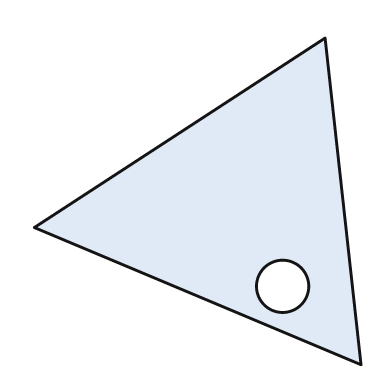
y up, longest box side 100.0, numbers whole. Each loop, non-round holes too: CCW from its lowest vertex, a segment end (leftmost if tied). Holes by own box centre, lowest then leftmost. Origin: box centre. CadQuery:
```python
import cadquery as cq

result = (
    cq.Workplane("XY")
    .moveTo(50.0, -50.0)
    .lineTo(39.0, 50.0)
    .lineTo(-50.0, -8.0)
    .close()
    .moveTo(26.0, -26.0)
    .circle(8.0)
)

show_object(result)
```